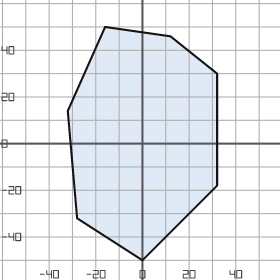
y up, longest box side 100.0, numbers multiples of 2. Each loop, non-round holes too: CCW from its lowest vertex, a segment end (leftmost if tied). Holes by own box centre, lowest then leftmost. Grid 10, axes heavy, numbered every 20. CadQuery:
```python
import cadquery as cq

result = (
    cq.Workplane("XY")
    .moveTo(0.0, -50.0)
    .lineTo(32.0, -18.0)
    .lineTo(32.0, 30.0)
    .lineTo(12.0, 46.0)
    .lineTo(-16.0, 50.0)
    .lineTo(-32.0, 14.0)
    .lineTo(-28.0, -32.0)
    .close()
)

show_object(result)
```